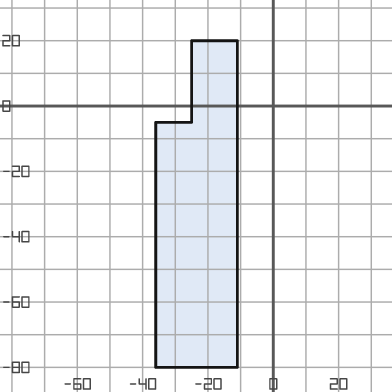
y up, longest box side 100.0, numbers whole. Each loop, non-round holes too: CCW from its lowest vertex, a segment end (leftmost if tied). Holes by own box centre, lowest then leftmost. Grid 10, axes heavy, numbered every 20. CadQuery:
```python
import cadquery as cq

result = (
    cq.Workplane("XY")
    .moveTo(-36.0, -80.0)
    .lineTo(-11.0, -80.0)
    .lineTo(-11.0, 20.0)
    .lineTo(-25.0, 20.0)
    .lineTo(-25.0, -5.0)
    .lineTo(-36.0, -5.0)
    .close()
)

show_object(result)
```